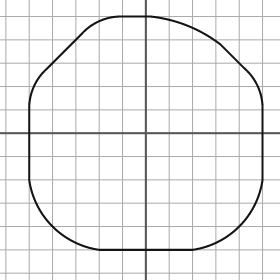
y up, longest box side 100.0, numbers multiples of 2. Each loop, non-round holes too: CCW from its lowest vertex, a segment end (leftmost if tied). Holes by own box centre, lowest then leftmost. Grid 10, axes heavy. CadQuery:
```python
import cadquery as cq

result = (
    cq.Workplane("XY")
    .moveTo(-20.0, -50.0)
    .lineTo(20.0, -50.0)
    .threePointArc((40.0, -40.0), (50.0, -20.0))
    .lineTo(50.0, 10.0)
    .threePointArc((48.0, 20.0), (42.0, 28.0))
    .lineTo(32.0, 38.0)
    .threePointArc((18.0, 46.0), (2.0, 50.0))
    .lineTo(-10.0, 50.0)
    .threePointArc((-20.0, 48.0), (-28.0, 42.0))
    .lineTo(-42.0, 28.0)
    .threePointArc((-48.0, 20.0), (-50.0, 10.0))
    .lineTo(-50.0, -20.0)
    .threePointArc((-40.0, -40.0), (-20.0, -50.0))
    .close()
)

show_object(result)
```